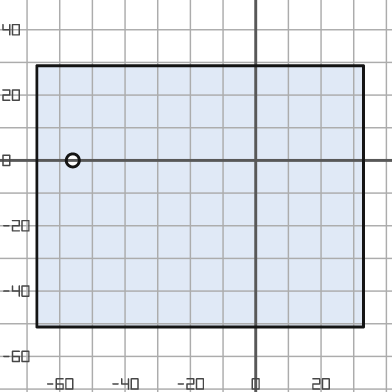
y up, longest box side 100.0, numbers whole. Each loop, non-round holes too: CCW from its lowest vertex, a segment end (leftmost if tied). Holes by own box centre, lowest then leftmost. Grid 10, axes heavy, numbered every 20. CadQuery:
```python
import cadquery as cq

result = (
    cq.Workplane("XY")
    .moveTo(-67.0, -51.0)
    .lineTo(33.0, -51.0)
    .lineTo(33.0, 29.0)
    .lineTo(-67.0, 29.0)
    .close()
    .moveTo(-56.0, 0.0)
    .circle(2.0)
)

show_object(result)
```